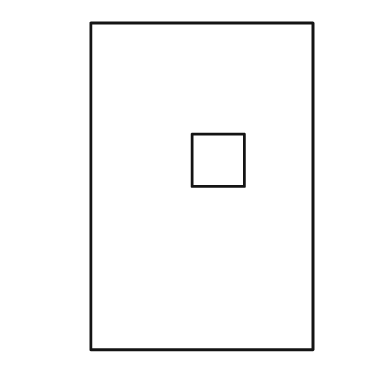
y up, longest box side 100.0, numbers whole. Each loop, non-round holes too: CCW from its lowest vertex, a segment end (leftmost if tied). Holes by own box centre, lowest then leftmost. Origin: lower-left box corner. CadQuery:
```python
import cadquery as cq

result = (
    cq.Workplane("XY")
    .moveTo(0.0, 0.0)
    .lineTo(68.0, 0.0)
    .lineTo(68.0, 100.0)
    .lineTo(0.0, 100.0)
    .close()
    .moveTo(31.0, 50.0)
    .lineTo(47.0, 50.0)
    .lineTo(47.0, 66.0)
    .lineTo(31.0, 66.0)
    .close()
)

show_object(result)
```